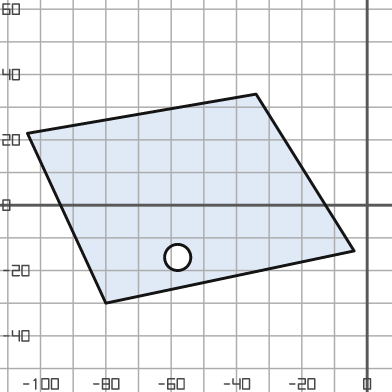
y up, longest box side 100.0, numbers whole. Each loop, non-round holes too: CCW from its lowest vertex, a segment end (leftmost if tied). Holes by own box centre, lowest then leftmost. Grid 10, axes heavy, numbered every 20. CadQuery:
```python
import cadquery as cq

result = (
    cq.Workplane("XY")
    .moveTo(-80.0, -30.0)
    .lineTo(-4.0, -14.0)
    .lineTo(-34.0, 34.0)
    .lineTo(-104.0, 22.0)
    .close()
    .moveTo(-58.0, -16.0)
    .circle(4.0)
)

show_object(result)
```